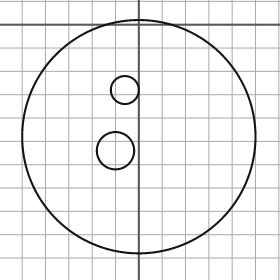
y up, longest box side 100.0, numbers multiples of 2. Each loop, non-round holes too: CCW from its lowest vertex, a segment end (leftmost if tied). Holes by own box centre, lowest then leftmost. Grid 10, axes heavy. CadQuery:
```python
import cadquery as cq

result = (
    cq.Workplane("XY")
    .moveTo(0.0, -48.0)
    .circle(50.0)
    .moveTo(-10.0, -54.0)
    .circle(8.0)
    .moveTo(-6.0, -28.0)
    .circle(6.0)
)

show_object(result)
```